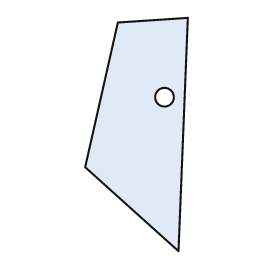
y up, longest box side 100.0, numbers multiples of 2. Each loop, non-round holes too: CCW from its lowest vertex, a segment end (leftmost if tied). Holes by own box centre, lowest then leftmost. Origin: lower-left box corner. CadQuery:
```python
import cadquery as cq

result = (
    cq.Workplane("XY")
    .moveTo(40.0, 0.0)
    .lineTo(44.0, 100.0)
    .lineTo(14.0, 98.0)
    .lineTo(0.0, 36.0)
    .close()
    .moveTo(34.0, 66.0)
    .circle(4.0)
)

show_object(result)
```